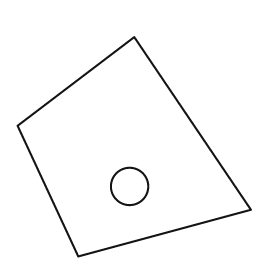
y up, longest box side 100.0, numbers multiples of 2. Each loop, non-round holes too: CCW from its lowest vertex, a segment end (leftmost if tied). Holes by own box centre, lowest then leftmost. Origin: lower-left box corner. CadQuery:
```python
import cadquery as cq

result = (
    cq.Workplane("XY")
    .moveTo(26.0, 0.0)
    .lineTo(100.0, 20.0)
    .lineTo(50.0, 94.0)
    .lineTo(0.0, 56.0)
    .close()
    .moveTo(48.0, 30.0)
    .circle(8.0)
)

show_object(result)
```